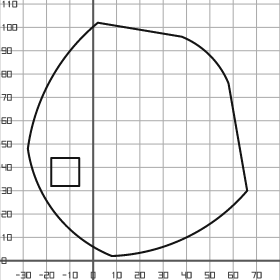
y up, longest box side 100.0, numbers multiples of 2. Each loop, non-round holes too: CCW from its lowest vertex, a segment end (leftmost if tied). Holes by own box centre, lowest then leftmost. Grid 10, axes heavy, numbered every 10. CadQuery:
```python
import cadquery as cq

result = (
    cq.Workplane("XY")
    .moveTo(8.0, 2.0)
    .threePointArc((40.0, 10.0), (66.0, 30.0))
    .lineTo(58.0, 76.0)
    .threePointArc((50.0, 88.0), (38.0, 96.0))
    .lineTo(2.0, 102.0)
    .threePointArc((-18.0, 78.0), (-28.0, 48.0))
    .threePointArc((-16.0, 20.0), (8.0, 2.0))
    .close()
    .moveTo(-18.0, 32.0)
    .lineTo(-6.0, 32.0)
    .lineTo(-6.0, 44.0)
    .lineTo(-18.0, 44.0)
    .close()
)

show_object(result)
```